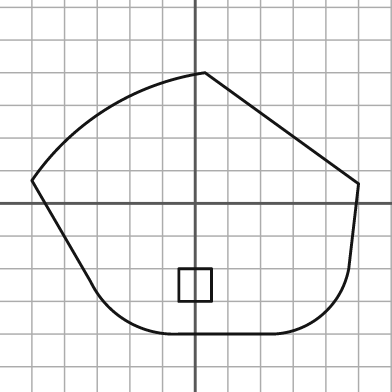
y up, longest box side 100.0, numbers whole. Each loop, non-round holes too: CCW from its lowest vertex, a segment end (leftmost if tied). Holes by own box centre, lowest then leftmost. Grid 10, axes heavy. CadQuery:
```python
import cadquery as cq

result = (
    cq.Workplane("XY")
    .moveTo(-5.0, -40.0)
    .lineTo(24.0, -40.0)
    .threePointArc((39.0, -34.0), (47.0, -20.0))
    .lineTo(50.0, 6.0)
    .lineTo(3.0, 40.0)
    .threePointArc((-27.0, 29.0), (-50.0, 7.0))
    .lineTo(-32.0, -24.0)
    .threePointArc((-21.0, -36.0), (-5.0, -40.0))
    .close()
    .moveTo(-5.0, -30.0)
    .lineTo(5.0, -30.0)
    .lineTo(5.0, -20.0)
    .lineTo(-5.0, -20.0)
    .close()
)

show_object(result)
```